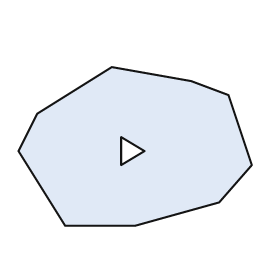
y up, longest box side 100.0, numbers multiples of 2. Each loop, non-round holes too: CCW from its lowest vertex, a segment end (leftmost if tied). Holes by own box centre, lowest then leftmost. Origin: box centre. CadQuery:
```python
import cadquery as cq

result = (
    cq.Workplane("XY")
    .moveTo(-30.0, -34.0)
    .lineTo(0.0, -34.0)
    .lineTo(36.0, -24.0)
    .lineTo(50.0, -8.0)
    .lineTo(40.0, 22.0)
    .lineTo(24.0, 28.0)
    .lineTo(-10.0, 34.0)
    .lineTo(-42.0, 14.0)
    .lineTo(-50.0, -2.0)
    .close()
    .moveTo(-6.0, -8.0)
    .lineTo(4.0, -2.0)
    .lineTo(-6.0, 4.0)
    .close()
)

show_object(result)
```